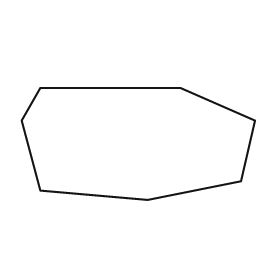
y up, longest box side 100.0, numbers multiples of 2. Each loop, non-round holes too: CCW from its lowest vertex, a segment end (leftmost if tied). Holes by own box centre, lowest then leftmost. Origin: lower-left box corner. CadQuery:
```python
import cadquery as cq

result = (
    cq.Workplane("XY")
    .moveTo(54.0, 0.0)
    .lineTo(94.0, 8.0)
    .lineTo(100.0, 34.0)
    .lineTo(68.0, 48.0)
    .lineTo(8.0, 48.0)
    .lineTo(0.0, 34.0)
    .lineTo(8.0, 4.0)
    .close()
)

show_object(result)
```